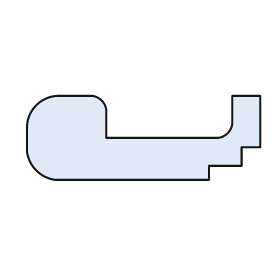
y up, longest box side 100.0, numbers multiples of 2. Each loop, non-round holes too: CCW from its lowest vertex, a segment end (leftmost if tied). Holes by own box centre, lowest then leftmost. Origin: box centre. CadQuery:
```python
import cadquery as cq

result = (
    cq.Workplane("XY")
    .moveTo(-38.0, -18.0)
    .lineTo(28.0, -18.0)
    .lineTo(28.0, -12.0)
    .lineTo(42.0, -12.0)
    .lineTo(42.0, -4.0)
    .lineTo(50.0, -4.0)
    .lineTo(50.0, 18.0)
    .lineTo(38.0, 18.0)
    .lineTo(38.0, 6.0)
    .threePointArc((36.0, 2.0), (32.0, 0.0))
    .lineTo(-16.0, 0.0)
    .lineTo(-16.0, 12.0)
    .threePointArc((-18.0, 16.0), (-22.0, 18.0))
    .lineTo(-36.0, 18.0)
    .threePointArc((-46.0, 14.0), (-50.0, 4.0))
    .lineTo(-50.0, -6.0)
    .threePointArc((-46.0, -14.0), (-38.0, -18.0))
    .close()
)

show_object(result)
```